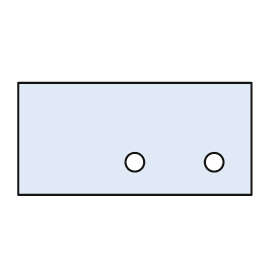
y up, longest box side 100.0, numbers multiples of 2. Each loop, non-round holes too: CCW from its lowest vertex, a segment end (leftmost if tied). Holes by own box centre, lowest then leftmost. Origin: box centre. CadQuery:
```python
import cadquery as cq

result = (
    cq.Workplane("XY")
    .moveTo(-50.0, -24.0)
    .lineTo(50.0, -24.0)
    .lineTo(50.0, 24.0)
    .lineTo(-50.0, 24.0)
    .close()
    .moveTo(0.0, -10.0)
    .circle(4.0)
    .moveTo(34.0, -10.0)
    .circle(4.0)
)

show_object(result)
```